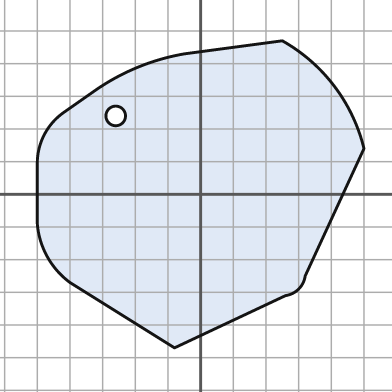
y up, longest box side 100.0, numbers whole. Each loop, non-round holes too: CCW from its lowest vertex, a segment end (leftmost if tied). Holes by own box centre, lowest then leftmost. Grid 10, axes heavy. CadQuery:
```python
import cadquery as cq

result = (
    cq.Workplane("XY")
    .moveTo(-8.0, -47.0)
    .lineTo(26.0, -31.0)
    .threePointArc((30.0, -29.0), (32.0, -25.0))
    .lineTo(50.0, 14.0)
    .threePointArc((41.0, 33.0), (25.0, 47.0))
    .lineTo(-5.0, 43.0)
    .threePointArc((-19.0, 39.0), (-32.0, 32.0))
    .lineTo(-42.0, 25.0)
    .threePointArc((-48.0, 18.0), (-50.0, 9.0))
    .lineTo(-50.0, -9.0)
    .threePointArc((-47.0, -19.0), (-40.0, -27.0))
    .close()
    .moveTo(-26.0, 24.0)
    .circle(3.0)
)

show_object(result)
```